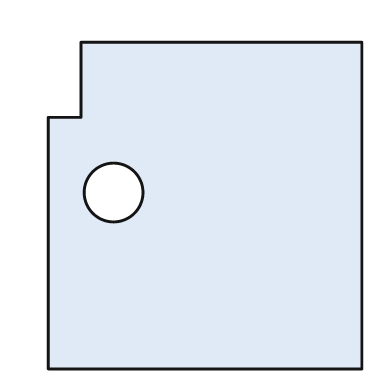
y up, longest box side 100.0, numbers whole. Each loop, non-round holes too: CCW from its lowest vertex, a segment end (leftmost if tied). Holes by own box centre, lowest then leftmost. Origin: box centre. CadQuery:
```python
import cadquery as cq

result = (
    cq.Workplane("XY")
    .moveTo(-48.0, -50.0)
    .lineTo(48.0, -50.0)
    .lineTo(48.0, 50.0)
    .lineTo(-38.0, 50.0)
    .lineTo(-38.0, 27.0)
    .lineTo(-48.0, 27.0)
    .close()
    .moveTo(-28.0, 4.0)
    .circle(9.0)
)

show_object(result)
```